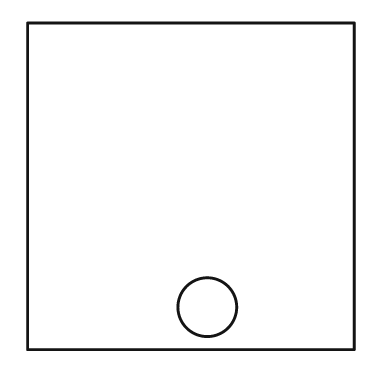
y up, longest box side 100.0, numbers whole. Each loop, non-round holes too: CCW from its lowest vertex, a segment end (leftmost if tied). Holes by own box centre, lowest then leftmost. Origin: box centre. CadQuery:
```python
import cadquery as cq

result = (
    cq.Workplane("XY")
    .moveTo(-50.0, -50.0)
    .lineTo(50.0, -50.0)
    .lineTo(50.0, 50.0)
    .lineTo(-50.0, 50.0)
    .close()
    .moveTo(5.0, -37.0)
    .circle(9.0)
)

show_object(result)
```